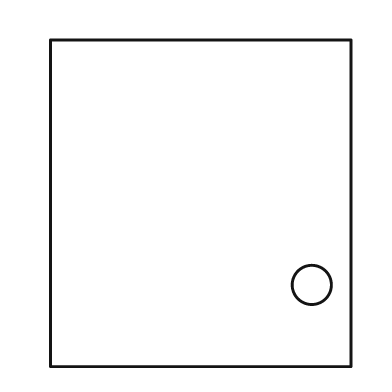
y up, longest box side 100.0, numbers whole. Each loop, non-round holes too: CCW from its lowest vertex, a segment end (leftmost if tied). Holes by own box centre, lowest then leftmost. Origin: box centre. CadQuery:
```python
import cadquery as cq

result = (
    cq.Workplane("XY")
    .moveTo(-46.0, -50.0)
    .lineTo(46.0, -50.0)
    .lineTo(46.0, 50.0)
    .lineTo(-46.0, 50.0)
    .close()
    .moveTo(34.0, -25.0)
    .circle(6.0)
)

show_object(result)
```